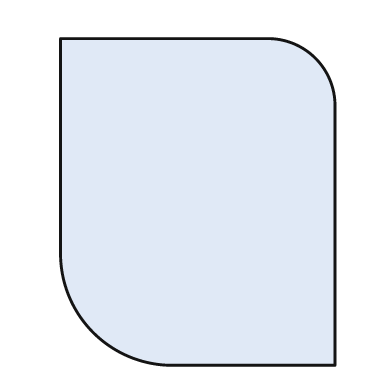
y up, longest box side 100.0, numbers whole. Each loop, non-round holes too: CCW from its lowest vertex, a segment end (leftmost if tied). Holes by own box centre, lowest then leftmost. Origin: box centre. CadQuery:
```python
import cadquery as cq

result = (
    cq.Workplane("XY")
    .moveTo(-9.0, -50.0)
    .lineTo(42.0, -50.0)
    .lineTo(42.0, 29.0)
    .threePointArc((36.0, 44.0), (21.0, 50.0))
    .lineTo(-42.0, 50.0)
    .lineTo(-42.0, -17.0)
    .threePointArc((-32.0, -40.0), (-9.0, -50.0))
    .close()
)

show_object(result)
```